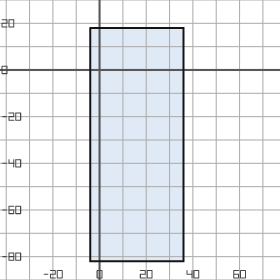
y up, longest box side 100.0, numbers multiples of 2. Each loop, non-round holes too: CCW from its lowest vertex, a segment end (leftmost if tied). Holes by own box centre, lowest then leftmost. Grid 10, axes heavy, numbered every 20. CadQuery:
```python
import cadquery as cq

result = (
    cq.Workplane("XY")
    .moveTo(-4.0, -82.0)
    .lineTo(36.0, -82.0)
    .lineTo(36.0, 18.0)
    .lineTo(-4.0, 18.0)
    .close()
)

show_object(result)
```